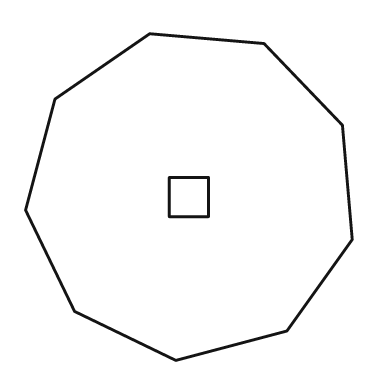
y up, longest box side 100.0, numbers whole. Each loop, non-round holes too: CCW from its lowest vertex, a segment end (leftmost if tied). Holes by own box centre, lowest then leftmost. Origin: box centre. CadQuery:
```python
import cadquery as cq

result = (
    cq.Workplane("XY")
    .moveTo(-4.0, -50.0)
    .lineTo(30.0, -41.0)
    .lineTo(50.0, -13.0)
    .lineTo(47.0, 22.0)
    .lineTo(23.0, 47.0)
    .lineTo(-12.0, 50.0)
    .lineTo(-41.0, 30.0)
    .lineTo(-50.0, -4.0)
    .lineTo(-35.0, -35.0)
    .close()
    .moveTo(-6.0, -6.0)
    .lineTo(6.0, -6.0)
    .lineTo(6.0, 6.0)
    .lineTo(-6.0, 6.0)
    .close()
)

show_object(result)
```